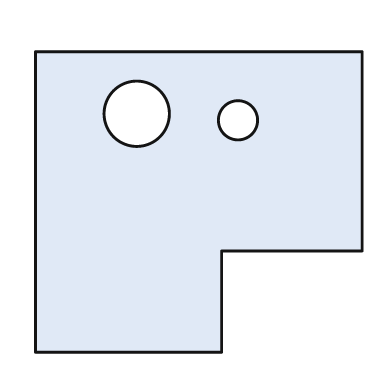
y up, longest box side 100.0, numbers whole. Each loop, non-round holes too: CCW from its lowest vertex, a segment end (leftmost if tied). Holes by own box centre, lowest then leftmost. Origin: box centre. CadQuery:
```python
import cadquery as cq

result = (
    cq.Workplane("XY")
    .moveTo(-50.0, -46.0)
    .lineTo(7.0, -46.0)
    .lineTo(7.0, -15.0)
    .lineTo(50.0, -15.0)
    .lineTo(50.0, 46.0)
    .lineTo(-50.0, 46.0)
    .close()
    .moveTo(12.0, 25.0)
    .circle(6.0)
    .moveTo(-19.0, 27.0)
    .circle(10.0)
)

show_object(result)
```